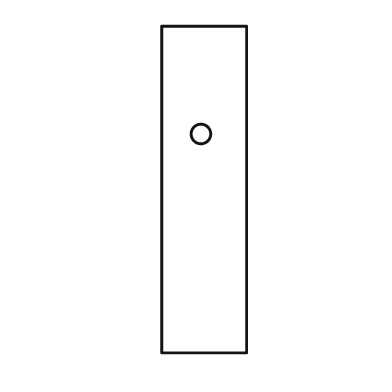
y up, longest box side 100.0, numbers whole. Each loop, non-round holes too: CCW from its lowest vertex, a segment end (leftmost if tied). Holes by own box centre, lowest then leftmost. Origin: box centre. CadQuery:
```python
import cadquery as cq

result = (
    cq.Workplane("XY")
    .moveTo(-13.0, -50.0)
    .lineTo(13.0, -50.0)
    .lineTo(13.0, 50.0)
    .lineTo(-13.0, 50.0)
    .close()
    .moveTo(-1.0, 17.0)
    .circle(3.0)
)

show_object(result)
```